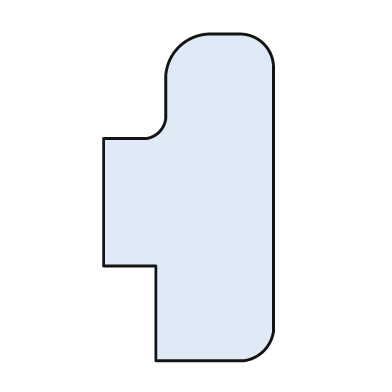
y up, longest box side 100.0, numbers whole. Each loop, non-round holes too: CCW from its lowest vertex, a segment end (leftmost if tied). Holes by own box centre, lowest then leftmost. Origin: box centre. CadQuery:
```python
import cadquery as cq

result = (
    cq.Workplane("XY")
    .moveTo(-10.0, -50.0)
    .lineTo(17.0, -50.0)
    .threePointArc((23.0, -47.0), (26.0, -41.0))
    .lineTo(26.0, 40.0)
    .threePointArc((23.0, 47.0), (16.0, 50.0))
    .lineTo(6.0, 50.0)
    .threePointArc((-3.0, 46.0), (-7.0, 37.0))
    .lineTo(-7.0, 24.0)
    .threePointArc((-9.0, 20.0), (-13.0, 18.0))
    .lineTo(-26.0, 18.0)
    .lineTo(-26.0, -21.0)
    .lineTo(-10.0, -21.0)
    .close()
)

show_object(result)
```